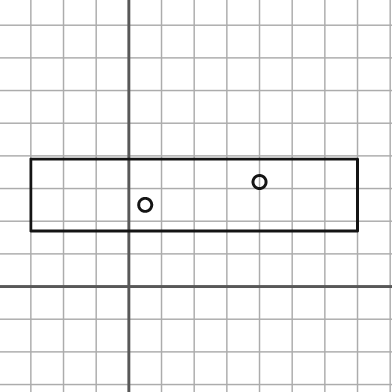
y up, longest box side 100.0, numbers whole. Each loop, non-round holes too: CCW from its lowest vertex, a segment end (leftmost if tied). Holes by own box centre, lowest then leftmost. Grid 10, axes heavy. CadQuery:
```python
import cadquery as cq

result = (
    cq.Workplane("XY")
    .moveTo(-30.0, 17.0)
    .lineTo(70.0, 17.0)
    .lineTo(70.0, 39.0)
    .lineTo(-30.0, 39.0)
    .close()
    .moveTo(5.0, 25.0)
    .circle(2.0)
    .moveTo(40.0, 32.0)
    .circle(2.0)
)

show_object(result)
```